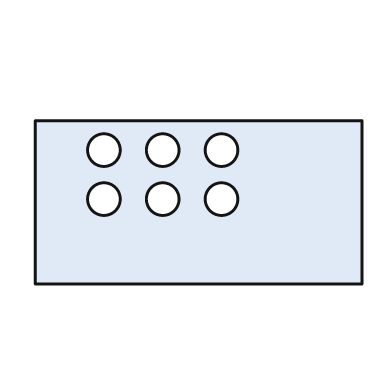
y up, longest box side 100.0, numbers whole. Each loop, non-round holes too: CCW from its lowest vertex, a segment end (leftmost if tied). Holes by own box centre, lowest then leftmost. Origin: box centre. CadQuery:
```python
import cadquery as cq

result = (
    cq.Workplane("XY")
    .moveTo(-50.0, -25.0)
    .lineTo(50.0, -25.0)
    .lineTo(50.0, 25.0)
    .lineTo(-50.0, 25.0)
    .close()
    .moveTo(-29.0, 1.0)
    .circle(5.0)
    .moveTo(-11.0, 1.0)
    .circle(5.0)
    .moveTo(7.0, 1.0)
    .circle(5.0)
    .moveTo(-29.0, 16.0)
    .circle(5.0)
    .moveTo(-11.0, 16.0)
    .circle(5.0)
    .moveTo(7.0, 16.0)
    .circle(5.0)
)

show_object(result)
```